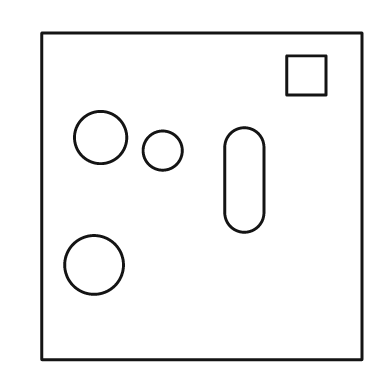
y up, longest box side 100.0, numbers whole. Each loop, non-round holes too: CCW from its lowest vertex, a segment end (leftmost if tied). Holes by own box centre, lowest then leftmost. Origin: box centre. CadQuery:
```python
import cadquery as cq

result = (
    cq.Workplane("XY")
    .moveTo(-49.0, -50.0)
    .lineTo(49.0, -50.0)
    .lineTo(49.0, 50.0)
    .lineTo(-49.0, 50.0)
    .close()
    .moveTo(-33.0, -21.0)
    .circle(9.0)
    .moveTo(7.0, -5.0)
    .threePointArc((13.0, -11.0), (19.0, -5.0))
    .lineTo(19.0, 15.0)
    .threePointArc((13.0, 21.0), (7.0, 15.0))
    .close()
    .moveTo(-12.0, 14.0)
    .circle(6.0)
    .moveTo(-31.0, 18.0)
    .circle(8.0)
    .moveTo(26.0, 31.0)
    .lineTo(38.0, 31.0)
    .lineTo(38.0, 43.0)
    .lineTo(26.0, 43.0)
    .close()
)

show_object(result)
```